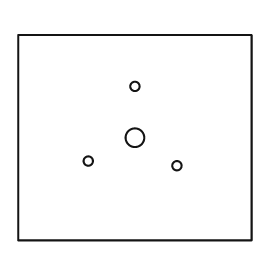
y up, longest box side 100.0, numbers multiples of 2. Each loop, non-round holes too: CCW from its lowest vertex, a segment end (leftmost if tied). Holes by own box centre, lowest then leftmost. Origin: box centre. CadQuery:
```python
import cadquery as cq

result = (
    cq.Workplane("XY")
    .moveTo(-50.0, -44.0)
    .lineTo(50.0, -44.0)
    .lineTo(50.0, 44.0)
    .lineTo(-50.0, 44.0)
    .close()
    .moveTo(18.0, -12.0)
    .circle(2.0)
    .moveTo(-20.0, -10.0)
    .circle(2.0)
    .moveTo(0.0, 0.0)
    .circle(4.0)
    .moveTo(0.0, 22.0)
    .circle(2.0)
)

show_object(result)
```